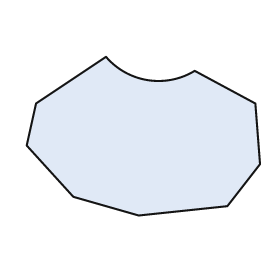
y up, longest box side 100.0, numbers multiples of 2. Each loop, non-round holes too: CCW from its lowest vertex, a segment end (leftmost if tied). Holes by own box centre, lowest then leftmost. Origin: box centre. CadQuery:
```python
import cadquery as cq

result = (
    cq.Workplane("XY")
    .moveTo(-2.0, -34.0)
    .lineTo(36.0, -30.0)
    .lineTo(50.0, -12.0)
    .lineTo(48.0, 14.0)
    .lineTo(22.0, 28.0)
    .threePointArc((2.0, 24.0), (-16.0, 34.0))
    .lineTo(-46.0, 14.0)
    .lineTo(-50.0, -4.0)
    .lineTo(-30.0, -26.0)
    .close()
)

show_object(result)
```